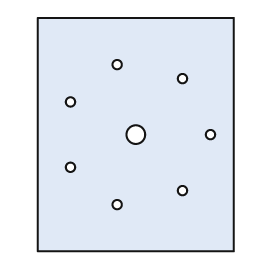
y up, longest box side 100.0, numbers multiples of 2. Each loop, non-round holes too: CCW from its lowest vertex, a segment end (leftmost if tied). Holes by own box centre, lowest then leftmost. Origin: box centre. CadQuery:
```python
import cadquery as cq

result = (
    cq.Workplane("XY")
    .moveTo(-42.0, -50.0)
    .lineTo(42.0, -50.0)
    .lineTo(42.0, 50.0)
    .lineTo(-42.0, 50.0)
    .close()
    .moveTo(-8.0, -30.0)
    .circle(2.0)
    .moveTo(20.0, -24.0)
    .circle(2.0)
    .moveTo(-28.0, -14.0)
    .circle(2.0)
    .moveTo(0.0, 0.0)
    .circle(4.0)
    .moveTo(32.0, 0.0)
    .circle(2.0)
    .moveTo(-28.0, 14.0)
    .circle(2.0)
    .moveTo(20.0, 24.0)
    .circle(2.0)
    .moveTo(-8.0, 30.0)
    .circle(2.0)
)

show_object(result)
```